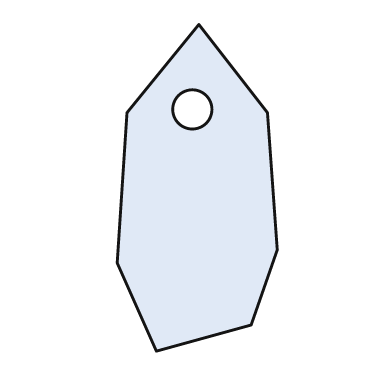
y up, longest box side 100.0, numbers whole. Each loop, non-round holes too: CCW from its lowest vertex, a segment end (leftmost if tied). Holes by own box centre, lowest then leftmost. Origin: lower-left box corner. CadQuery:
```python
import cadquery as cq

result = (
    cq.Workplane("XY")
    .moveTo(12.0, 0.0)
    .lineTo(41.0, 8.0)
    .lineTo(49.0, 31.0)
    .lineTo(46.0, 73.0)
    .lineTo(25.0, 100.0)
    .lineTo(3.0, 73.0)
    .lineTo(0.0, 27.0)
    .close()
    .moveTo(23.0, 74.0)
    .circle(6.0)
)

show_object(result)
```